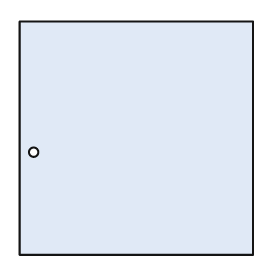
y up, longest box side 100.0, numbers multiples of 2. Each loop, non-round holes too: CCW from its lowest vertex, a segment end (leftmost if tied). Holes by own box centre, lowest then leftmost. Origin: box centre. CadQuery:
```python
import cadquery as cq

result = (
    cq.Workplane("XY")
    .moveTo(-50.0, -50.0)
    .lineTo(50.0, -50.0)
    .lineTo(50.0, 50.0)
    .lineTo(-50.0, 50.0)
    .close()
    .moveTo(-44.0, -6.0)
    .circle(2.0)
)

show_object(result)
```